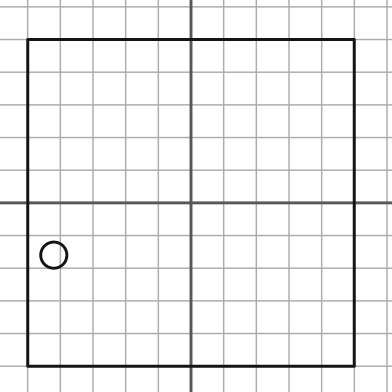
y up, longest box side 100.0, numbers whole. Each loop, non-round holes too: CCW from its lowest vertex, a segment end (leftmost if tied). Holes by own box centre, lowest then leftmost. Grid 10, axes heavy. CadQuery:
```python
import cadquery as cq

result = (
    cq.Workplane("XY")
    .moveTo(-50.0, -50.0)
    .lineTo(50.0, -50.0)
    .lineTo(50.0, 50.0)
    .lineTo(-50.0, 50.0)
    .close()
    .moveTo(-42.0, -16.0)
    .circle(4.0)
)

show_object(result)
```